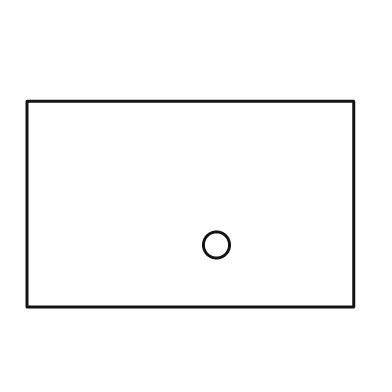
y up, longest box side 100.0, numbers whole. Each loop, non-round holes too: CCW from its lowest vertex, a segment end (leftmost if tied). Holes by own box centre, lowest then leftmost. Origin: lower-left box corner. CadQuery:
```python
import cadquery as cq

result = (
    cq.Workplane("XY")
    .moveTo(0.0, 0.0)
    .lineTo(100.0, 0.0)
    .lineTo(100.0, 63.0)
    .lineTo(0.0, 63.0)
    .close()
    .moveTo(58.0, 19.0)
    .circle(4.0)
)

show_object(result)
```